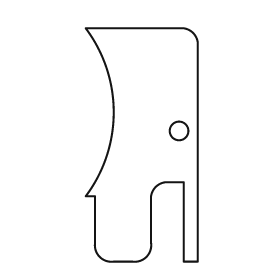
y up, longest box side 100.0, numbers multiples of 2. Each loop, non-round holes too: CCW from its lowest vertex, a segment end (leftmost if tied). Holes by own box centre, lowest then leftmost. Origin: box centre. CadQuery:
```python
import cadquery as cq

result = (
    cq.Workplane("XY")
    .moveTo(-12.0, -50.0)
    .lineTo(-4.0, -50.0)
    .threePointArc((2.0, -48.0), (4.0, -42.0))
    .lineTo(4.0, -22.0)
    .threePointArc((6.0, -18.0), (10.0, -16.0))
    .lineTo(18.0, -16.0)
    .lineTo(18.0, -50.0)
    .lineTo(24.0, -50.0)
    .lineTo(24.0, 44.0)
    .threePointArc((22.0, 48.0), (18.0, 50.0))
    .lineTo(-24.0, 50.0)
    .threePointArc((-12.0, 14.0), (-24.0, -22.0))
    .lineTo(-20.0, -22.0)
    .lineTo(-20.0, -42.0)
    .threePointArc((-18.0, -48.0), (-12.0, -50.0))
    .close()
    .moveTo(16.0, 6.0)
    .circle(4.0)
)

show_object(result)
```